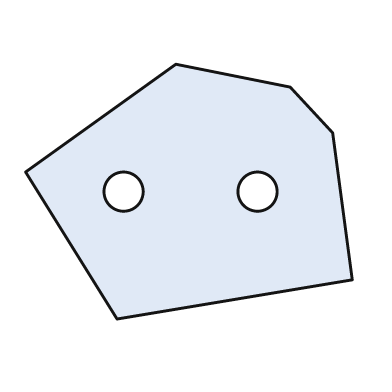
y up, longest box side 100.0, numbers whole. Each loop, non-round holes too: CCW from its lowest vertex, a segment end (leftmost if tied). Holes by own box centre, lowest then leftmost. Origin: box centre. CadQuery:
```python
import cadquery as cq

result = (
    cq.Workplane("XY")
    .moveTo(-22.0, -39.0)
    .lineTo(50.0, -27.0)
    .lineTo(44.0, 18.0)
    .lineTo(31.0, 32.0)
    .lineTo(-4.0, 39.0)
    .lineTo(-50.0, 6.0)
    .close()
    .moveTo(-20.0, 0.0)
    .circle(6.0)
    .moveTo(21.0, 0.0)
    .circle(6.0)
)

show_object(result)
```